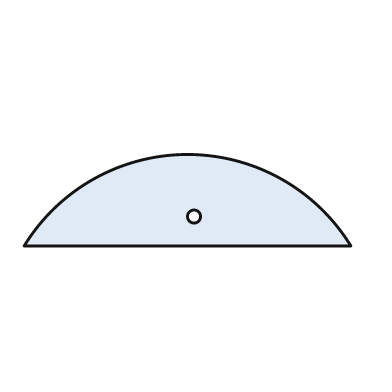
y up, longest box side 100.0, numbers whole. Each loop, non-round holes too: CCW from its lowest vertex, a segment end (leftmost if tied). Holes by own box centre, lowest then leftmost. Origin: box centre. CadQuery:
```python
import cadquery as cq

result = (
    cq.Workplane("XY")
    .moveTo(-50.0, -14.0)
    .lineTo(50.0, -14.0)
    .threePointArc((0.0, 14.0), (-50.0, -14.0))
    .close()
    .moveTo(2.0, -5.0)
    .circle(2.0)
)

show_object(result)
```